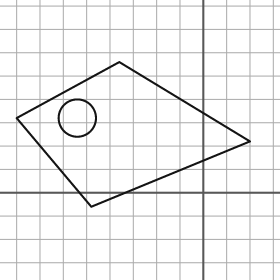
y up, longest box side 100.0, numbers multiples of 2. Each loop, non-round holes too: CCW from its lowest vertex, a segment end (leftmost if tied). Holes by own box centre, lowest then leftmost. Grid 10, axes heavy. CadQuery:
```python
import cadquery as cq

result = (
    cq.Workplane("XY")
    .moveTo(-48.0, -6.0)
    .lineTo(20.0, 22.0)
    .lineTo(-36.0, 56.0)
    .lineTo(-80.0, 32.0)
    .close()
    .moveTo(-54.0, 32.0)
    .circle(8.0)
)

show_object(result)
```